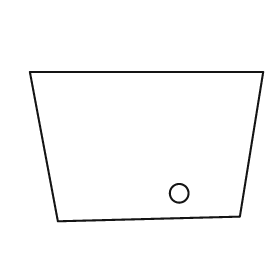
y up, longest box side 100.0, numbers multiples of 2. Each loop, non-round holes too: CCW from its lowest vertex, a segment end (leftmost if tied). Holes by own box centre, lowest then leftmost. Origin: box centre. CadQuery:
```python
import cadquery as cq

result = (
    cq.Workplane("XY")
    .moveTo(-38.0, -32.0)
    .lineTo(40.0, -30.0)
    .lineTo(50.0, 32.0)
    .lineTo(-50.0, 32.0)
    .close()
    .moveTo(14.0, -20.0)
    .circle(4.0)
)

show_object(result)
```